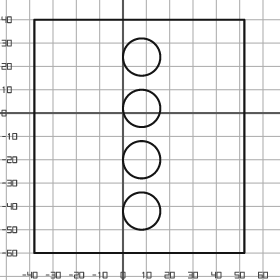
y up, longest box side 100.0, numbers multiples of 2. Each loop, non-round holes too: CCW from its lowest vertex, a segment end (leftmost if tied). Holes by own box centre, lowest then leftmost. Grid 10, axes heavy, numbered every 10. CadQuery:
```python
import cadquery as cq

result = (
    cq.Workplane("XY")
    .moveTo(-38.0, -60.0)
    .lineTo(52.0, -60.0)
    .lineTo(52.0, 40.0)
    .lineTo(-38.0, 40.0)
    .close()
    .moveTo(8.0, -42.0)
    .circle(8.0)
    .moveTo(8.0, -20.0)
    .circle(8.0)
    .moveTo(8.0, 2.0)
    .circle(8.0)
    .moveTo(8.0, 24.0)
    .circle(8.0)
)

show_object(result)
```